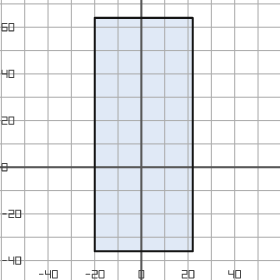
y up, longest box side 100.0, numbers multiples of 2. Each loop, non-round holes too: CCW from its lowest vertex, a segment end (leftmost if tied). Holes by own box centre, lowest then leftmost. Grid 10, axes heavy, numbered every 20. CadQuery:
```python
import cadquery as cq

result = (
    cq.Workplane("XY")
    .moveTo(-20.0, -36.0)
    .lineTo(22.0, -36.0)
    .lineTo(22.0, 64.0)
    .lineTo(-20.0, 64.0)
    .close()
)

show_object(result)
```